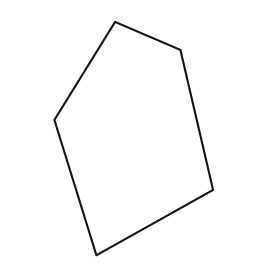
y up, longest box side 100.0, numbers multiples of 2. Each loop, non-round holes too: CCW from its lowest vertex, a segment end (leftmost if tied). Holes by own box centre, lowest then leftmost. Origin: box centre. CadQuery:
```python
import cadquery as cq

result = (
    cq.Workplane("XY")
    .moveTo(-16.0, -50.0)
    .lineTo(34.0, -22.0)
    .lineTo(20.0, 38.0)
    .lineTo(-8.0, 50.0)
    .lineTo(-34.0, 8.0)
    .close()
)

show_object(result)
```